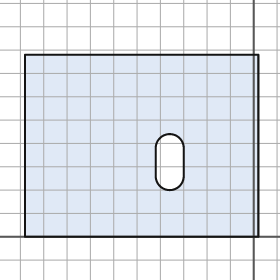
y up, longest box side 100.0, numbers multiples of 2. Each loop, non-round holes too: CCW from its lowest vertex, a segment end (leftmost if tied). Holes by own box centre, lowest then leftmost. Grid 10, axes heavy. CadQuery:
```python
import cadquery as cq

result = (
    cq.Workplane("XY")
    .moveTo(-98.0, 0.0)
    .lineTo(2.0, 0.0)
    .lineTo(2.0, 78.0)
    .lineTo(-98.0, 78.0)
    .close()
    .moveTo(-42.0, 26.0)
    .threePointArc((-36.0, 20.0), (-30.0, 26.0))
    .lineTo(-30.0, 38.0)
    .threePointArc((-36.0, 44.0), (-42.0, 38.0))
    .close()
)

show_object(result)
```